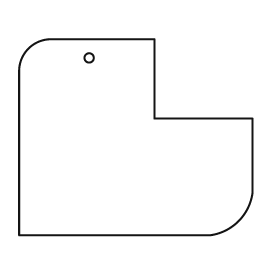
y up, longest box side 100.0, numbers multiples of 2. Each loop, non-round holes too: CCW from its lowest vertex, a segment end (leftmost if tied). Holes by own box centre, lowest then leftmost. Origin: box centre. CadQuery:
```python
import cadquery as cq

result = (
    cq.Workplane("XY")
    .moveTo(-50.0, -42.0)
    .lineTo(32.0, -42.0)
    .threePointArc((44.0, -36.0), (50.0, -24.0))
    .lineTo(50.0, 8.0)
    .lineTo(8.0, 8.0)
    .lineTo(8.0, 42.0)
    .lineTo(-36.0, 42.0)
    .threePointArc((-46.0, 38.0), (-50.0, 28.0))
    .close()
    .moveTo(-20.0, 34.0)
    .circle(2.0)
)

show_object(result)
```